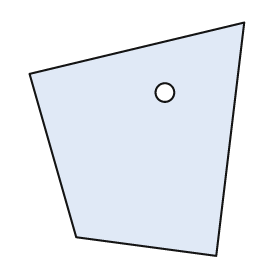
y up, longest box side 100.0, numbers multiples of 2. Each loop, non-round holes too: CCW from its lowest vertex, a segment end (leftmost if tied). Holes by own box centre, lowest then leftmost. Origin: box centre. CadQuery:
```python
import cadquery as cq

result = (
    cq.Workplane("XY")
    .moveTo(34.0, -50.0)
    .lineTo(46.0, 50.0)
    .lineTo(-46.0, 28.0)
    .lineTo(-26.0, -42.0)
    .close()
    .moveTo(12.0, 20.0)
    .circle(4.0)
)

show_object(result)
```